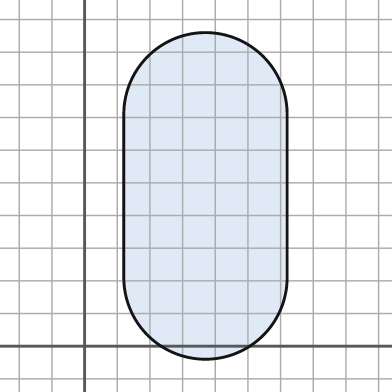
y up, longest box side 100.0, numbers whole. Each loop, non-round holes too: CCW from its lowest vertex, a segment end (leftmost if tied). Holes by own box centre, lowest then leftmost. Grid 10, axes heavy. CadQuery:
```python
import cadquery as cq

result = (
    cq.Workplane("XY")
    .moveTo(12.0, 21.0)
    .threePointArc((37.0, -4.0), (62.0, 21.0))
    .lineTo(62.0, 71.0)
    .threePointArc((37.0, 96.0), (12.0, 71.0))
    .close()
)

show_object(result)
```